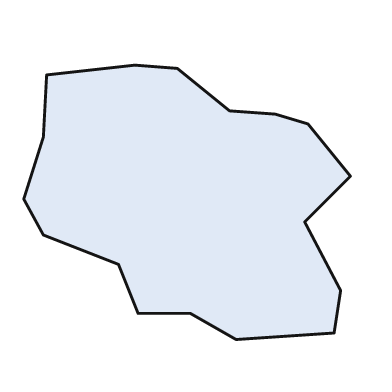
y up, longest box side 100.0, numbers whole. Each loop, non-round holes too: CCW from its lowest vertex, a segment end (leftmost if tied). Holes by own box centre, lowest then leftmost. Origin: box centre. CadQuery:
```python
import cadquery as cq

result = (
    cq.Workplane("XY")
    .moveTo(15.0, -42.0)
    .lineTo(45.0, -40.0)
    .lineTo(47.0, -27.0)
    .lineTo(36.0, -6.0)
    .lineTo(50.0, 8.0)
    .lineTo(37.0, 24.0)
    .lineTo(27.0, 27.0)
    .lineTo(13.0, 28.0)
    .lineTo(-3.0, 41.0)
    .lineTo(-16.0, 42.0)
    .lineTo(-43.0, 39.0)
    .lineTo(-44.0, 20.0)
    .lineTo(-50.0, 1.0)
    .lineTo(-44.0, -10.0)
    .lineTo(-21.0, -19.0)
    .lineTo(-15.0, -34.0)
    .lineTo(1.0, -34.0)
    .close()
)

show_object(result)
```